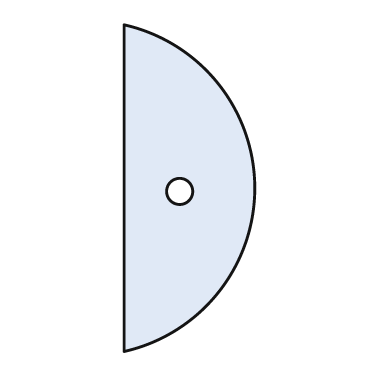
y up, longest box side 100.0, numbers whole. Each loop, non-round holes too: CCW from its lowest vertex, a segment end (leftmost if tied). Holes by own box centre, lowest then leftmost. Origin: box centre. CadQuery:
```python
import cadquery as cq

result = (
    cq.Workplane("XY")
    .moveTo(-20.0, -50.0)
    .threePointArc((20.0, 0.0), (-20.0, 50.0))
    .close()
    .moveTo(-3.0, -1.0)
    .circle(4.0)
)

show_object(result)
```